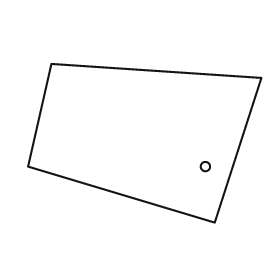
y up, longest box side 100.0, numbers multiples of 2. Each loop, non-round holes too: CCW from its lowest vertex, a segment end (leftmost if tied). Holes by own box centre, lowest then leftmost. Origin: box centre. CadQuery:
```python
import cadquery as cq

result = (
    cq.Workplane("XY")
    .moveTo(30.0, -34.0)
    .lineTo(50.0, 28.0)
    .lineTo(-40.0, 34.0)
    .lineTo(-50.0, -10.0)
    .close()
    .moveTo(26.0, -10.0)
    .circle(2.0)
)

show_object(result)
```